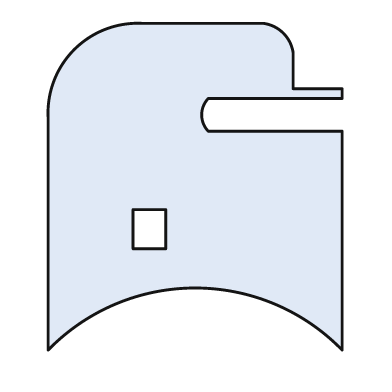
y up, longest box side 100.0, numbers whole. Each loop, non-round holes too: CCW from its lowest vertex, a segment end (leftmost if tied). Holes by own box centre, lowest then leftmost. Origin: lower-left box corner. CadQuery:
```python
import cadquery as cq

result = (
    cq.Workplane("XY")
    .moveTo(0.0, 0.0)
    .threePointArc((45.0, 19.0), (90.0, 0.0))
    .lineTo(90.0, 67.0)
    .lineTo(49.0, 67.0)
    .threePointArc((47.0, 72.0), (49.0, 77.0))
    .lineTo(90.0, 77.0)
    .lineTo(90.0, 80.0)
    .lineTo(75.0, 80.0)
    .lineTo(75.0, 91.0)
    .threePointArc((72.0, 97.0), (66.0, 100.0))
    .lineTo(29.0, 100.0)
    .threePointArc((8.0, 92.0), (0.0, 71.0))
    .close()
    .moveTo(26.0, 31.0)
    .lineTo(36.0, 31.0)
    .lineTo(36.0, 43.0)
    .lineTo(26.0, 43.0)
    .close()
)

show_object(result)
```